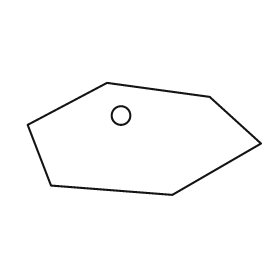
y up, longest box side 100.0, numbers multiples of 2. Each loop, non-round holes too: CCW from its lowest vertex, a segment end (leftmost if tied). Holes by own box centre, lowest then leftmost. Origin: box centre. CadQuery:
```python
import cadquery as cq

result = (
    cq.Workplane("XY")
    .moveTo(12.0, -24.0)
    .lineTo(50.0, -2.0)
    .lineTo(28.0, 18.0)
    .lineTo(-16.0, 24.0)
    .lineTo(-50.0, 6.0)
    .lineTo(-40.0, -20.0)
    .close()
    .moveTo(-10.0, 10.0)
    .circle(4.0)
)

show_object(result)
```